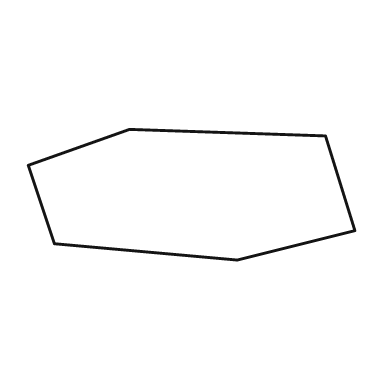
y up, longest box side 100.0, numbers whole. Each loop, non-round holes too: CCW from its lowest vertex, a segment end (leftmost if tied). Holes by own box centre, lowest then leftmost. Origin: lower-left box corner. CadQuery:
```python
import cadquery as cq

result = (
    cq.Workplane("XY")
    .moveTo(64.0, 0.0)
    .lineTo(100.0, 9.0)
    .lineTo(91.0, 38.0)
    .lineTo(31.0, 40.0)
    .lineTo(0.0, 29.0)
    .lineTo(8.0, 5.0)
    .close()
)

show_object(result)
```